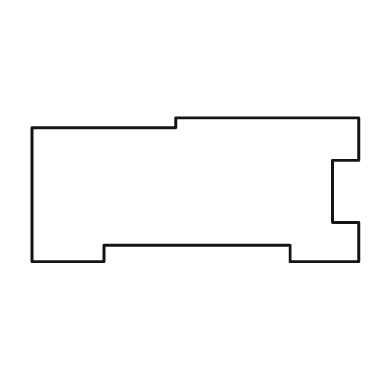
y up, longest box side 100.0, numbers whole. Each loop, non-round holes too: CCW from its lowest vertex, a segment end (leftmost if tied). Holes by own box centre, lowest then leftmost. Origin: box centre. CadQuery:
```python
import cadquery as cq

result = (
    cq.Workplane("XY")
    .moveTo(-50.0, -22.0)
    .lineTo(-28.0, -22.0)
    .lineTo(-28.0, -17.0)
    .lineTo(29.0, -17.0)
    .lineTo(29.0, -22.0)
    .lineTo(50.0, -22.0)
    .lineTo(50.0, -10.0)
    .lineTo(42.0, -10.0)
    .lineTo(42.0, 9.0)
    .lineTo(50.0, 9.0)
    .lineTo(50.0, 22.0)
    .lineTo(-6.0, 22.0)
    .lineTo(-6.0, 19.0)
    .lineTo(-50.0, 19.0)
    .close()
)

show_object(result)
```